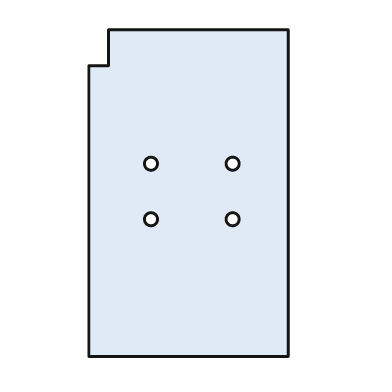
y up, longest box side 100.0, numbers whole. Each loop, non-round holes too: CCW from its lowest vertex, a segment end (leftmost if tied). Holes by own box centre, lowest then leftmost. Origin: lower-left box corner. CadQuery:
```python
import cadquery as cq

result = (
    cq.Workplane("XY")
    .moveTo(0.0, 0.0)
    .lineTo(61.0, 0.0)
    .lineTo(61.0, 100.0)
    .lineTo(6.0, 100.0)
    .lineTo(6.0, 89.0)
    .lineTo(0.0, 89.0)
    .close()
    .moveTo(19.0, 42.0)
    .circle(2.0)
    .moveTo(44.0, 42.0)
    .circle(2.0)
    .moveTo(19.0, 59.0)
    .circle(2.0)
    .moveTo(44.0, 59.0)
    .circle(2.0)
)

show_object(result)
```